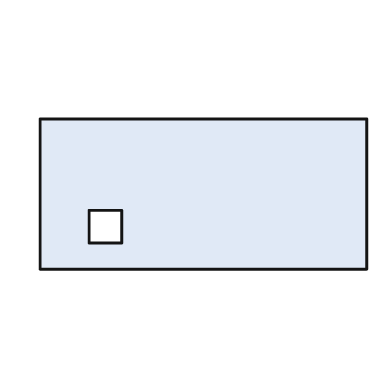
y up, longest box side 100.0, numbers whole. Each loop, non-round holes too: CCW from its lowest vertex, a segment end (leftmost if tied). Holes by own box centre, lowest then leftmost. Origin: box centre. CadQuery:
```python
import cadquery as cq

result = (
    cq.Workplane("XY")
    .moveTo(-50.0, -23.0)
    .lineTo(50.0, -23.0)
    .lineTo(50.0, 23.0)
    .lineTo(-50.0, 23.0)
    .close()
    .moveTo(-35.0, -15.0)
    .lineTo(-25.0, -15.0)
    .lineTo(-25.0, -5.0)
    .lineTo(-35.0, -5.0)
    .close()
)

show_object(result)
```